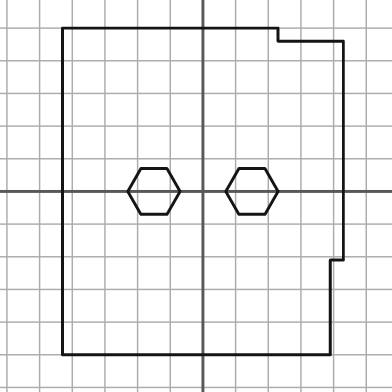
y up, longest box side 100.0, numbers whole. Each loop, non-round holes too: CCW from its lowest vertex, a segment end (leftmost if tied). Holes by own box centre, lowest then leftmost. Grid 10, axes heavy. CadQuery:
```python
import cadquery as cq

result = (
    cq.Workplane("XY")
    .moveTo(-43.0, -50.0)
    .lineTo(39.0, -50.0)
    .lineTo(39.0, -21.0)
    .lineTo(43.0, -21.0)
    .lineTo(43.0, 46.0)
    .lineTo(23.0, 46.0)
    .lineTo(23.0, 50.0)
    .lineTo(-43.0, 50.0)
    .close()
    .moveTo(-19.0, -7.0)
    .lineTo(-11.0, -7.0)
    .lineTo(-7.0, 0.0)
    .lineTo(-11.0, 7.0)
    .lineTo(-19.0, 7.0)
    .lineTo(-23.0, 0.0)
    .close()
    .moveTo(11.0, -7.0)
    .lineTo(19.0, -7.0)
    .lineTo(23.0, 0.0)
    .lineTo(19.0, 7.0)
    .lineTo(11.0, 7.0)
    .lineTo(7.0, 0.0)
    .close()
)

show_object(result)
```